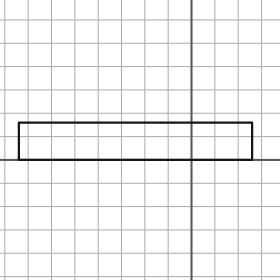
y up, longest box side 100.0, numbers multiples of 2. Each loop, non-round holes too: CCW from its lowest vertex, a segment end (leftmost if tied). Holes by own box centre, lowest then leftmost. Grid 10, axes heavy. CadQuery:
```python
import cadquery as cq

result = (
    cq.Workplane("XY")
    .moveTo(-74.0, 0.0)
    .lineTo(26.0, 0.0)
    .lineTo(26.0, 16.0)
    .lineTo(-74.0, 16.0)
    .close()
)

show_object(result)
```